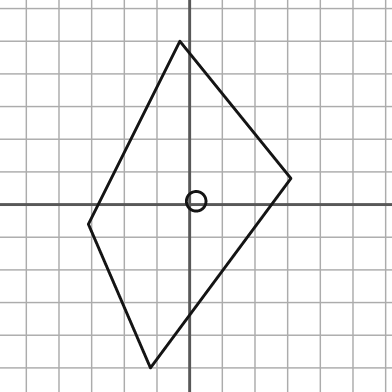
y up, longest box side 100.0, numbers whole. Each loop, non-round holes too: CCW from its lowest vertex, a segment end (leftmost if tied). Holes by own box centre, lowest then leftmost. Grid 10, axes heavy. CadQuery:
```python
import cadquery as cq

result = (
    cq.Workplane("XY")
    .moveTo(-12.0, -50.0)
    .lineTo(31.0, 8.0)
    .lineTo(-3.0, 50.0)
    .lineTo(-31.0, -6.0)
    .close()
    .moveTo(2.0, 1.0)
    .circle(3.0)
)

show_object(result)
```